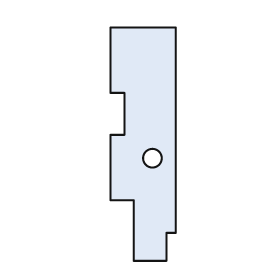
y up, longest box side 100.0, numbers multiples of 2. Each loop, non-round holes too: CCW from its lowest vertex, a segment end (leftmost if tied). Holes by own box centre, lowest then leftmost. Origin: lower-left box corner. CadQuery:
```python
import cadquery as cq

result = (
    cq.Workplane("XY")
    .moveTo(10.0, 0.0)
    .lineTo(24.0, 0.0)
    .lineTo(24.0, 12.0)
    .lineTo(28.0, 12.0)
    .lineTo(28.0, 100.0)
    .lineTo(0.0, 100.0)
    .lineTo(0.0, 72.0)
    .lineTo(6.0, 72.0)
    .lineTo(6.0, 54.0)
    .lineTo(0.0, 54.0)
    .lineTo(0.0, 26.0)
    .lineTo(10.0, 26.0)
    .close()
    .moveTo(18.0, 44.0)
    .circle(4.0)
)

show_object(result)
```